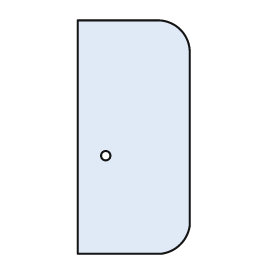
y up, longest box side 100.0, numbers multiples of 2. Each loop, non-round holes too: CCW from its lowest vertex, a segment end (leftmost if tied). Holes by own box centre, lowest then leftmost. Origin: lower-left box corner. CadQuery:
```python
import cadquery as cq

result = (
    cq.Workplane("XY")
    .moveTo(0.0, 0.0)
    .lineTo(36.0, 0.0)
    .threePointArc((44.0, 4.0), (48.0, 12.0))
    .lineTo(48.0, 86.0)
    .threePointArc((44.0, 96.0), (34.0, 100.0))
    .lineTo(0.0, 100.0)
    .close()
    .moveTo(12.0, 42.0)
    .circle(2.0)
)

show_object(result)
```